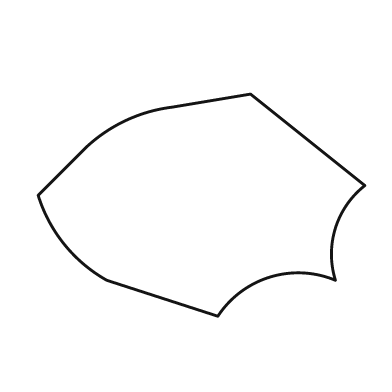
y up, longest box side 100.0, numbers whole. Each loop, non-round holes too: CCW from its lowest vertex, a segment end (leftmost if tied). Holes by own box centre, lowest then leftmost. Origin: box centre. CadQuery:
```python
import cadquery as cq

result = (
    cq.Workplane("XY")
    .moveTo(5.0, -34.0)
    .threePointArc((21.0, -22.0), (41.0, -23.0))
    .threePointArc((41.0, -7.0), (50.0, 6.0))
    .lineTo(15.0, 34.0)
    .lineTo(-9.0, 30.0)
    .threePointArc((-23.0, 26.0), (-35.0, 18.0))
    .lineTo(-50.0, 3.0)
    .threePointArc((-42.0, -12.0), (-29.0, -23.0))
    .close()
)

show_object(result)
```